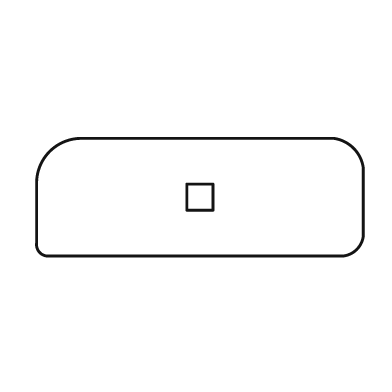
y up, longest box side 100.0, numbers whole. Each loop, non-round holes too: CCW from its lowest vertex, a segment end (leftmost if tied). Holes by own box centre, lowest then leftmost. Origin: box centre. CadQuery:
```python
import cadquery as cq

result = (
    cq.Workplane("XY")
    .moveTo(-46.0, -18.0)
    .lineTo(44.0, -18.0)
    .threePointArc((48.0, -16.0), (50.0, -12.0))
    .lineTo(50.0, 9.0)
    .threePointArc((47.0, 15.0), (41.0, 18.0))
    .lineTo(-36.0, 18.0)
    .threePointArc((-46.0, 14.0), (-50.0, 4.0))
    .lineTo(-50.0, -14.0)
    .threePointArc((-49.0, -17.0), (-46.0, -18.0))
    .close()
    .moveTo(-4.0, -4.0)
    .lineTo(4.0, -4.0)
    .lineTo(4.0, 4.0)
    .lineTo(-4.0, 4.0)
    .close()
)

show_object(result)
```